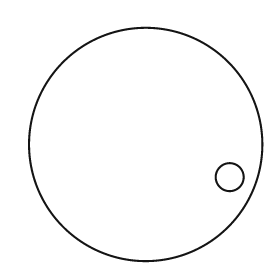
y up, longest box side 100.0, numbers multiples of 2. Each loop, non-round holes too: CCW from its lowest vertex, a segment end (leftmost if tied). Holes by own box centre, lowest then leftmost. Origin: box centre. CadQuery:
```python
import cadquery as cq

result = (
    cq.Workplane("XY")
    .moveTo(0.0, 0.0)
    .circle(50.0)
    .moveTo(36.0, -14.0)
    .circle(6.0)
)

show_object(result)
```